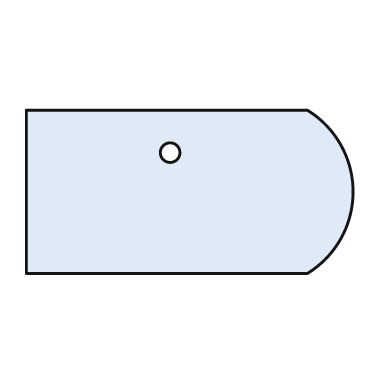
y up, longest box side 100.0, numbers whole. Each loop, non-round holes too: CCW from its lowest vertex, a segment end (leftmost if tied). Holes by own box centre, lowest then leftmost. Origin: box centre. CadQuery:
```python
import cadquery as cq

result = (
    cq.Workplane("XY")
    .moveTo(-50.0, -25.0)
    .lineTo(36.0, -25.0)
    .threePointArc((50.0, 0.0), (36.0, 25.0))
    .lineTo(-50.0, 25.0)
    .close()
    .moveTo(-6.0, 12.0)
    .circle(3.0)
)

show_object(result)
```